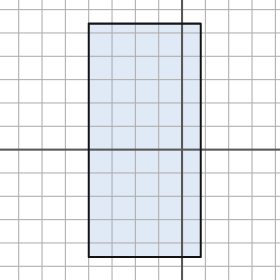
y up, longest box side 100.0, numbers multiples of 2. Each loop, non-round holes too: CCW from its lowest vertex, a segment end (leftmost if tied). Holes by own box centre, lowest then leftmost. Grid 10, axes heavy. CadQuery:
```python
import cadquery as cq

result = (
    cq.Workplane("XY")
    .moveTo(-40.0, -46.0)
    .lineTo(8.0, -46.0)
    .lineTo(8.0, 54.0)
    .lineTo(-40.0, 54.0)
    .close()
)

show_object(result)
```